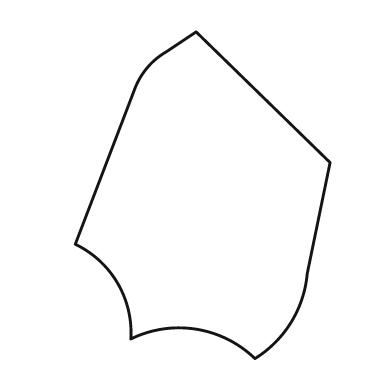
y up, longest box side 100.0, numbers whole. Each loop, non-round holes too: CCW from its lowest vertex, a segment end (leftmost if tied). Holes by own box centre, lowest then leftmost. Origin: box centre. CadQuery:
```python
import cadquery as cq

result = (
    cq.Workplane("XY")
    .moveTo(16.0, -50.0)
    .threePointArc((27.0, -39.0), (32.0, -24.0))
    .lineTo(39.0, 10.0)
    .lineTo(-2.0, 50.0)
    .lineTo(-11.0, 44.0)
    .threePointArc((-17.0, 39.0), (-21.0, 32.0))
    .lineTo(-39.0, -15.0)
    .threePointArc((-26.0, -27.0), (-22.0, -44.0))
    .threePointArc((-2.0, -41.0), (16.0, -50.0))
    .close()
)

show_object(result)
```